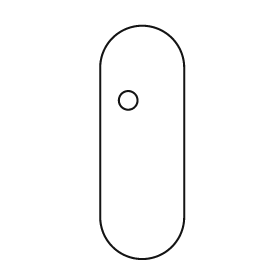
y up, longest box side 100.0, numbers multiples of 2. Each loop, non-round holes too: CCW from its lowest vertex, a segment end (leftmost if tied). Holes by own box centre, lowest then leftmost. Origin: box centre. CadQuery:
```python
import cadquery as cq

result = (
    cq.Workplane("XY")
    .moveTo(-18.0, -32.0)
    .threePointArc((0.0, -50.0), (18.0, -32.0))
    .lineTo(18.0, 32.0)
    .threePointArc((0.0, 50.0), (-18.0, 32.0))
    .close()
    .moveTo(-6.0, 18.0)
    .circle(4.0)
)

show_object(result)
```